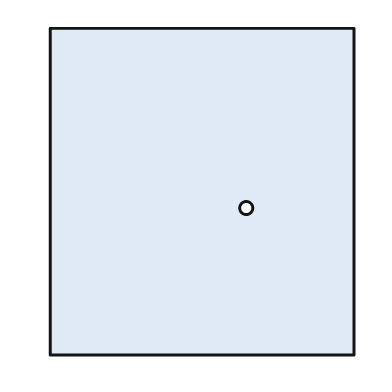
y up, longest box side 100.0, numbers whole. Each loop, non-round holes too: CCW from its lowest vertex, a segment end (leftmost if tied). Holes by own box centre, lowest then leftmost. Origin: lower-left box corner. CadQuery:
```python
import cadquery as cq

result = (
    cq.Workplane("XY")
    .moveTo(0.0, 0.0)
    .lineTo(93.0, 0.0)
    .lineTo(93.0, 100.0)
    .lineTo(0.0, 100.0)
    .close()
    .moveTo(60.0, 45.0)
    .circle(2.0)
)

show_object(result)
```